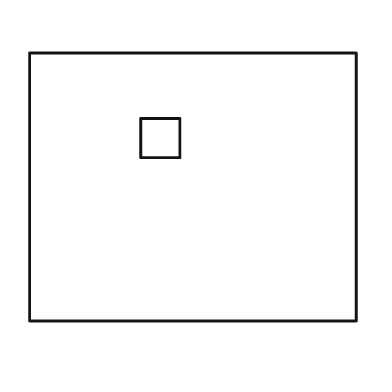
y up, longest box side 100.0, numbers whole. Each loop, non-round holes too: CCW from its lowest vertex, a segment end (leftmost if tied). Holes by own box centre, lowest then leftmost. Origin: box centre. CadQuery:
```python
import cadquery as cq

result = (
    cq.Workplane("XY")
    .moveTo(-50.0, -41.0)
    .lineTo(50.0, -41.0)
    .lineTo(50.0, 41.0)
    .lineTo(-50.0, 41.0)
    .close()
    .moveTo(-16.0, 9.0)
    .lineTo(-4.0, 9.0)
    .lineTo(-4.0, 21.0)
    .lineTo(-16.0, 21.0)
    .close()
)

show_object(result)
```